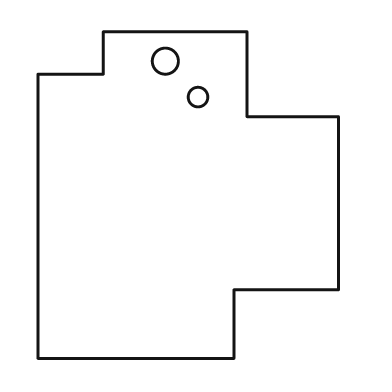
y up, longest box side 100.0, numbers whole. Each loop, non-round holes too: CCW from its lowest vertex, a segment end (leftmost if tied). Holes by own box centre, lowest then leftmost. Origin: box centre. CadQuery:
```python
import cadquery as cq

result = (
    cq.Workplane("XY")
    .moveTo(-46.0, -50.0)
    .lineTo(14.0, -50.0)
    .lineTo(14.0, -29.0)
    .lineTo(46.0, -29.0)
    .lineTo(46.0, 24.0)
    .lineTo(18.0, 24.0)
    .lineTo(18.0, 50.0)
    .lineTo(-26.0, 50.0)
    .lineTo(-26.0, 37.0)
    .lineTo(-46.0, 37.0)
    .close()
    .moveTo(3.0, 30.0)
    .circle(3.0)
    .moveTo(-7.0, 41.0)
    .circle(4.0)
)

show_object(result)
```